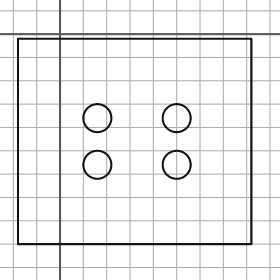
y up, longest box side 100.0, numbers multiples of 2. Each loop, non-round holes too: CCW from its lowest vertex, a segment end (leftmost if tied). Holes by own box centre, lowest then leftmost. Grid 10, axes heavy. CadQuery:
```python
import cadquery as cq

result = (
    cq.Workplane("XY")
    .moveTo(-18.0, -90.0)
    .lineTo(82.0, -90.0)
    .lineTo(82.0, -2.0)
    .lineTo(-18.0, -2.0)
    .close()
    .moveTo(16.0, -56.0)
    .circle(6.0)
    .moveTo(50.0, -56.0)
    .circle(6.0)
    .moveTo(16.0, -36.0)
    .circle(6.0)
    .moveTo(50.0, -36.0)
    .circle(6.0)
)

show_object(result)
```